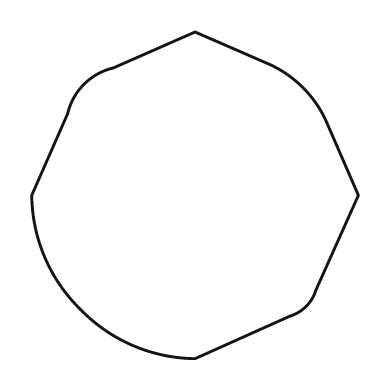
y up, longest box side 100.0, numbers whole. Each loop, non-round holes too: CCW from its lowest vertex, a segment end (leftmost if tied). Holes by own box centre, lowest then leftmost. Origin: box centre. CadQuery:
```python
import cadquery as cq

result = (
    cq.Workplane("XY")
    .moveTo(0.0, -50.0)
    .lineTo(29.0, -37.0)
    .threePointArc((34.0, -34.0), (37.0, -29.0))
    .lineTo(50.0, 0.0)
    .lineTo(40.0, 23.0)
    .threePointArc((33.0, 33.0), (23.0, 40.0))
    .lineTo(0.0, 50.0)
    .lineTo(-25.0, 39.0)
    .threePointArc((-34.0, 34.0), (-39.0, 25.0))
    .lineTo(-50.0, 0.0)
    .threePointArc((-46.0, -19.0), (-35.0, -35.0))
    .threePointArc((-19.0, -46.0), (0.0, -50.0))
    .close()
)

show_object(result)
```